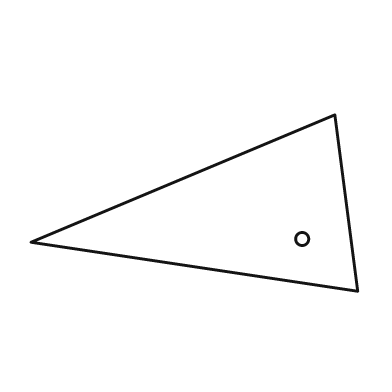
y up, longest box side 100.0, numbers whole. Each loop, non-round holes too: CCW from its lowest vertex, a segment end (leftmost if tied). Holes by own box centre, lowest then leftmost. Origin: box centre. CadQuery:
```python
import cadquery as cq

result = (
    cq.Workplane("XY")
    .moveTo(50.0, -27.0)
    .lineTo(43.0, 27.0)
    .lineTo(-50.0, -12.0)
    .close()
    .moveTo(33.0, -11.0)
    .circle(2.0)
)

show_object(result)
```